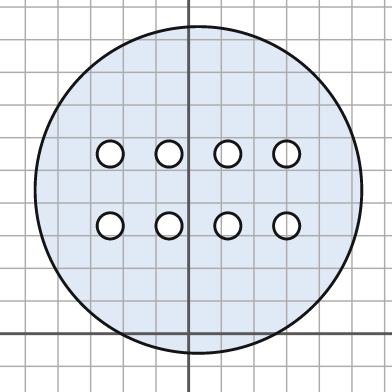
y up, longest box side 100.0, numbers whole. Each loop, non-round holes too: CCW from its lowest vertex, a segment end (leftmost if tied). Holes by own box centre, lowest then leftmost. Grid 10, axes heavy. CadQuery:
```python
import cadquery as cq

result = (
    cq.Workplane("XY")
    .moveTo(3.0, 44.0)
    .circle(50.0)
    .moveTo(-24.0, 33.0)
    .circle(4.0)
    .moveTo(-6.0, 33.0)
    .circle(4.0)
    .moveTo(12.0, 33.0)
    .circle(4.0)
    .moveTo(30.0, 33.0)
    .circle(4.0)
    .moveTo(-24.0, 55.0)
    .circle(4.0)
    .moveTo(-6.0, 55.0)
    .circle(4.0)
    .moveTo(12.0, 55.0)
    .circle(4.0)
    .moveTo(30.0, 55.0)
    .circle(4.0)
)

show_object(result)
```